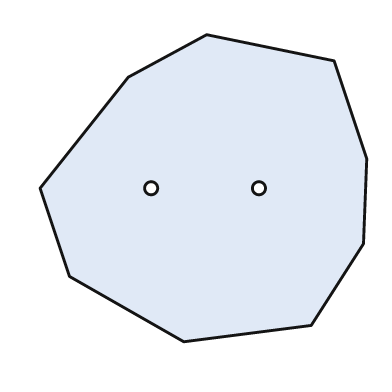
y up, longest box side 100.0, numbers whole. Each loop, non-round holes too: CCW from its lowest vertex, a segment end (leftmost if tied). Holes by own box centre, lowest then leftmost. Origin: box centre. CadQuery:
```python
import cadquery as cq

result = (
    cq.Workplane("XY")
    .moveTo(-6.0, -47.0)
    .lineTo(33.0, -42.0)
    .lineTo(49.0, -17.0)
    .lineTo(50.0, 9.0)
    .lineTo(40.0, 39.0)
    .lineTo(1.0, 47.0)
    .lineTo(-23.0, 34.0)
    .lineTo(-50.0, 0.0)
    .lineTo(-41.0, -27.0)
    .close()
    .moveTo(-16.0, 0.0)
    .circle(2.0)
    .moveTo(17.0, 0.0)
    .circle(2.0)
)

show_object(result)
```